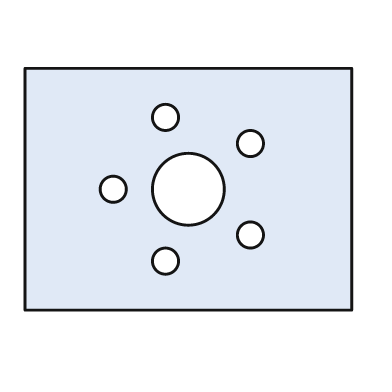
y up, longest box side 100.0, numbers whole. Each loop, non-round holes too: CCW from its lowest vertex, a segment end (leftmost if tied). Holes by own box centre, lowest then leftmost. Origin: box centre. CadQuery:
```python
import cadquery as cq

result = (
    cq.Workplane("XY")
    .moveTo(-50.0, -37.0)
    .lineTo(50.0, -37.0)
    .lineTo(50.0, 37.0)
    .lineTo(-50.0, 37.0)
    .close()
    .moveTo(-7.0, -22.0)
    .circle(4.0)
    .moveTo(19.0, -14.0)
    .circle(4.0)
    .moveTo(-23.0, 0.0)
    .circle(4.0)
    .moveTo(0.0, 0.0)
    .circle(11.0)
    .moveTo(19.0, 14.0)
    .circle(4.0)
    .moveTo(-7.0, 22.0)
    .circle(4.0)
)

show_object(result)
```